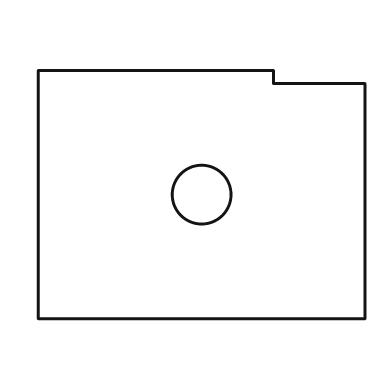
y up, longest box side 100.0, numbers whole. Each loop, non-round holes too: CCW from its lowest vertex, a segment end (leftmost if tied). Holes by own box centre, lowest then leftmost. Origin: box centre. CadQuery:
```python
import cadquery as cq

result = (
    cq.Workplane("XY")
    .moveTo(-50.0, -38.0)
    .lineTo(50.0, -38.0)
    .lineTo(50.0, 34.0)
    .lineTo(22.0, 34.0)
    .lineTo(22.0, 38.0)
    .lineTo(-50.0, 38.0)
    .close()
    .moveTo(0.0, 0.0)
    .circle(9.0)
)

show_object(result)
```